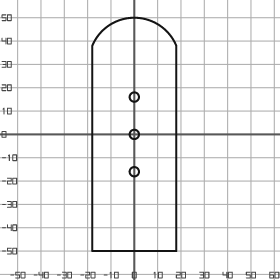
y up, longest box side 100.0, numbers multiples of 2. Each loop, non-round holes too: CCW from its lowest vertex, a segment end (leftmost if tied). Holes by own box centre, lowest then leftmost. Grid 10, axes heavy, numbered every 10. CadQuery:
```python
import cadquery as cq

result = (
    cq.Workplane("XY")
    .moveTo(-18.0, -50.0)
    .lineTo(18.0, -50.0)
    .lineTo(18.0, 38.0)
    .threePointArc((0.0, 50.0), (-18.0, 38.0))
    .close()
    .moveTo(0.0, -16.0)
    .circle(2.0)
    .moveTo(0.0, 0.0)
    .circle(2.0)
    .moveTo(0.0, 16.0)
    .circle(2.0)
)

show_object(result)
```